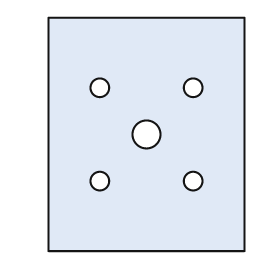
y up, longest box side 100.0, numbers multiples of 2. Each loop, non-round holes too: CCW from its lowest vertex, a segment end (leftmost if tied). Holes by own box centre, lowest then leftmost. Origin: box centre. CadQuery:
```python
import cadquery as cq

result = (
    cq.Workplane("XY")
    .moveTo(-42.0, -50.0)
    .lineTo(42.0, -50.0)
    .lineTo(42.0, 50.0)
    .lineTo(-42.0, 50.0)
    .close()
    .moveTo(-20.0, -20.0)
    .circle(4.0)
    .moveTo(20.0, -20.0)
    .circle(4.0)
    .moveTo(0.0, 0.0)
    .circle(6.0)
    .moveTo(-20.0, 20.0)
    .circle(4.0)
    .moveTo(20.0, 20.0)
    .circle(4.0)
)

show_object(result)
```